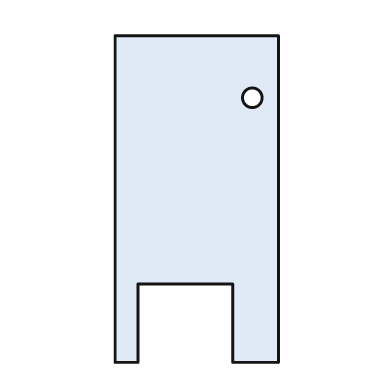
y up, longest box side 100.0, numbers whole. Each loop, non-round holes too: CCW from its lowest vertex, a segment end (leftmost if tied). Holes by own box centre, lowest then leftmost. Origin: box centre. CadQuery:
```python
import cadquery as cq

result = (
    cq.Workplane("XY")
    .moveTo(-25.0, -50.0)
    .lineTo(-18.0, -50.0)
    .lineTo(-18.0, -26.0)
    .lineTo(11.0, -26.0)
    .lineTo(11.0, -50.0)
    .lineTo(25.0, -50.0)
    .lineTo(25.0, 50.0)
    .lineTo(-25.0, 50.0)
    .close()
    .moveTo(17.0, 31.0)
    .circle(3.0)
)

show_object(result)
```